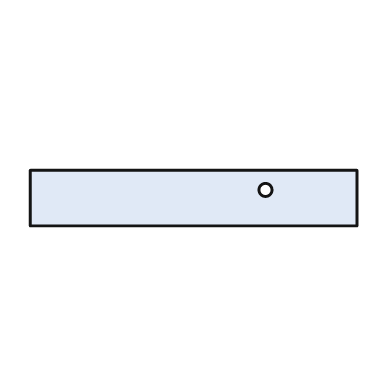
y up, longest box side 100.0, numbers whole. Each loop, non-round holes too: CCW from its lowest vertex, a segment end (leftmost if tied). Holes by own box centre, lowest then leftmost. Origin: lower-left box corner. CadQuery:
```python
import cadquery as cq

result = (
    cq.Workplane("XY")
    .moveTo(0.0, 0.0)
    .lineTo(100.0, 0.0)
    .lineTo(100.0, 17.0)
    .lineTo(0.0, 17.0)
    .close()
    .moveTo(72.0, 11.0)
    .circle(2.0)
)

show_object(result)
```